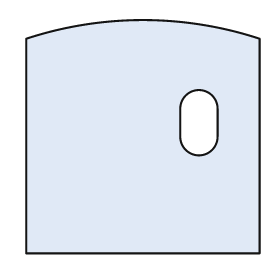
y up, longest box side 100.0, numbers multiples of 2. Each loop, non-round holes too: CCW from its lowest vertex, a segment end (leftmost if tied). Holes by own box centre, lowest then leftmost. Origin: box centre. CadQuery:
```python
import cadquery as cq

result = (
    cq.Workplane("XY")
    .moveTo(-50.0, -50.0)
    .lineTo(50.0, -50.0)
    .lineTo(50.0, 42.0)
    .threePointArc((0.0, 50.0), (-50.0, 42.0))
    .close()
    .moveTo(16.0, 0.0)
    .threePointArc((24.0, -8.0), (32.0, 0.0))
    .lineTo(32.0, 12.0)
    .threePointArc((24.0, 20.0), (16.0, 12.0))
    .close()
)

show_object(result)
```